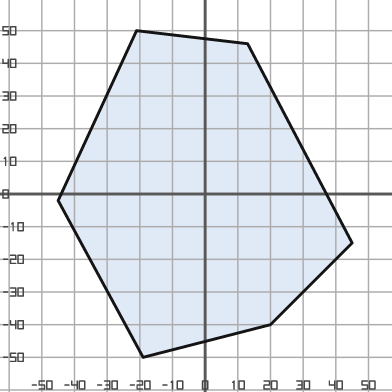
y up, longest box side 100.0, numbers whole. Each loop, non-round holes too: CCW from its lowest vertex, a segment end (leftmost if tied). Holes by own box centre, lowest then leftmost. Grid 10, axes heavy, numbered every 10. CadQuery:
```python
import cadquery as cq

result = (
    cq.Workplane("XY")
    .moveTo(-19.0, -50.0)
    .lineTo(20.0, -40.0)
    .lineTo(45.0, -15.0)
    .lineTo(13.0, 46.0)
    .lineTo(-21.0, 50.0)
    .lineTo(-45.0, -2.0)
    .close()
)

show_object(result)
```